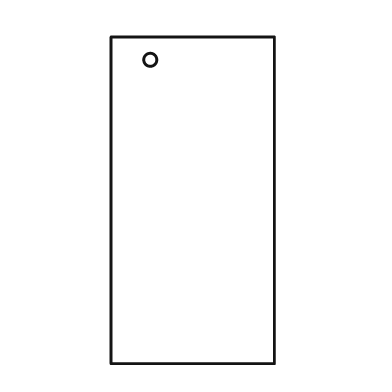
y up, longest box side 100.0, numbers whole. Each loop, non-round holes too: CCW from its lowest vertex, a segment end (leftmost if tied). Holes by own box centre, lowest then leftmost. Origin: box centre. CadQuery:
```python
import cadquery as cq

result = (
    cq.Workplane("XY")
    .moveTo(-25.0, -50.0)
    .lineTo(25.0, -50.0)
    .lineTo(25.0, 50.0)
    .lineTo(-25.0, 50.0)
    .close()
    .moveTo(-13.0, 43.0)
    .circle(2.0)
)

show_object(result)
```